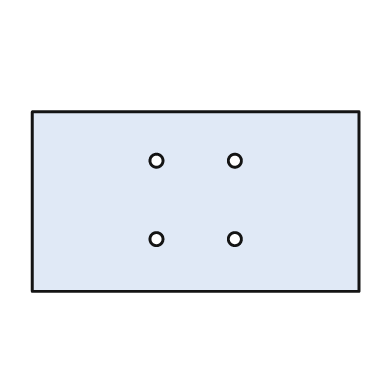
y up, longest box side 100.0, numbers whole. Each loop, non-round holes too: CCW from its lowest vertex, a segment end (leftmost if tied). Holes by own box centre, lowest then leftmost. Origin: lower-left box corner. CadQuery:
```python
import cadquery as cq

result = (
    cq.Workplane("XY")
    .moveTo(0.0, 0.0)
    .lineTo(100.0, 0.0)
    .lineTo(100.0, 55.0)
    .lineTo(0.0, 55.0)
    .close()
    .moveTo(38.0, 16.0)
    .circle(2.0)
    .moveTo(62.0, 16.0)
    .circle(2.0)
    .moveTo(38.0, 40.0)
    .circle(2.0)
    .moveTo(62.0, 40.0)
    .circle(2.0)
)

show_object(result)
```